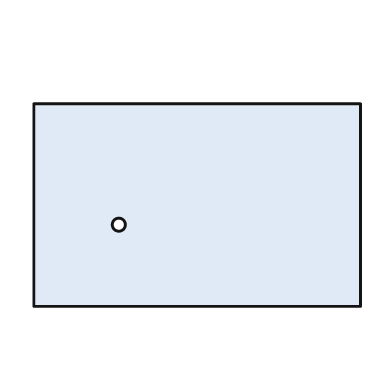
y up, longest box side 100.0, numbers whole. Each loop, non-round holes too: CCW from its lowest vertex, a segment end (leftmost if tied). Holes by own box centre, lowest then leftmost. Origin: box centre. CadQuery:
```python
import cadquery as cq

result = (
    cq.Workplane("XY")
    .moveTo(-50.0, -31.0)
    .lineTo(50.0, -31.0)
    .lineTo(50.0, 31.0)
    .lineTo(-50.0, 31.0)
    .close()
    .moveTo(-24.0, -6.0)
    .circle(2.0)
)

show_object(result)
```